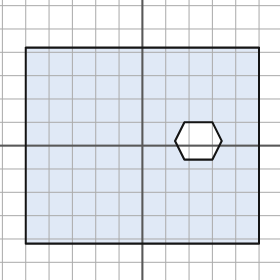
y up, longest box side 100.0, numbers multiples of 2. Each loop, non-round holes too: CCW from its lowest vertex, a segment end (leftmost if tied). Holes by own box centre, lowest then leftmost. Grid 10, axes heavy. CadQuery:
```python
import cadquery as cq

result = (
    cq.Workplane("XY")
    .moveTo(-50.0, -42.0)
    .lineTo(50.0, -42.0)
    .lineTo(50.0, 42.0)
    .lineTo(-50.0, 42.0)
    .close()
    .moveTo(18.0, -6.0)
    .lineTo(30.0, -6.0)
    .lineTo(34.0, 2.0)
    .lineTo(30.0, 10.0)
    .lineTo(18.0, 10.0)
    .lineTo(14.0, 2.0)
    .close()
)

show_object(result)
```